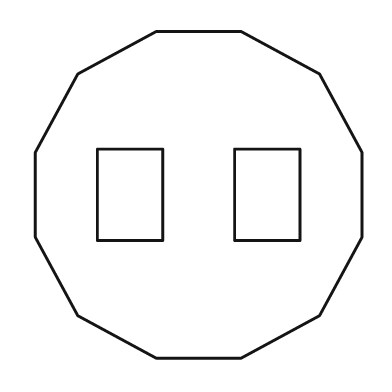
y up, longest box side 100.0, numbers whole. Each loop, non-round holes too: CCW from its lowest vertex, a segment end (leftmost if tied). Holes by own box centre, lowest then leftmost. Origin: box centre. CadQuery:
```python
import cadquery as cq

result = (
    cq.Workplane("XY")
    .moveTo(-13.0, -50.0)
    .lineTo(13.0, -50.0)
    .lineTo(37.0, -37.0)
    .lineTo(50.0, -13.0)
    .lineTo(50.0, 13.0)
    .lineTo(37.0, 37.0)
    .lineTo(13.0, 50.0)
    .lineTo(-13.0, 50.0)
    .lineTo(-37.0, 37.0)
    .lineTo(-50.0, 13.0)
    .lineTo(-50.0, -13.0)
    .lineTo(-37.0, -37.0)
    .close()
    .moveTo(-31.0, -14.0)
    .lineTo(-11.0, -14.0)
    .lineTo(-11.0, 14.0)
    .lineTo(-31.0, 14.0)
    .close()
    .moveTo(11.0, -14.0)
    .lineTo(31.0, -14.0)
    .lineTo(31.0, 14.0)
    .lineTo(11.0, 14.0)
    .close()
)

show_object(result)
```